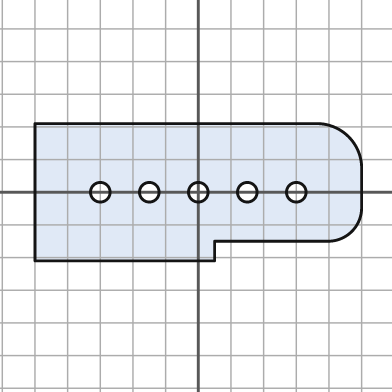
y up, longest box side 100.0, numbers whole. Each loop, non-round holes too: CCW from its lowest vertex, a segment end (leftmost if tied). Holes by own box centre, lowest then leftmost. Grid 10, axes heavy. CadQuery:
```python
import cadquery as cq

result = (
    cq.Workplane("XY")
    .moveTo(-50.0, -21.0)
    .lineTo(5.0, -21.0)
    .lineTo(5.0, -15.0)
    .lineTo(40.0, -15.0)
    .threePointArc((47.0, -12.0), (50.0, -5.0))
    .lineTo(50.0, 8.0)
    .threePointArc((46.0, 17.0), (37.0, 21.0))
    .lineTo(-50.0, 21.0)
    .close()
    .moveTo(-30.0, 0.0)
    .circle(3.0)
    .moveTo(-15.0, 0.0)
    .circle(3.0)
    .moveTo(0.0, 0.0)
    .circle(3.0)
    .moveTo(15.0, 0.0)
    .circle(3.0)
    .moveTo(30.0, 0.0)
    .circle(3.0)
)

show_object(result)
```